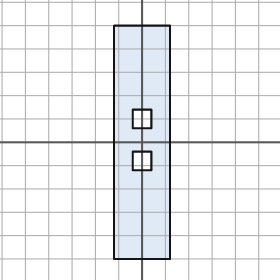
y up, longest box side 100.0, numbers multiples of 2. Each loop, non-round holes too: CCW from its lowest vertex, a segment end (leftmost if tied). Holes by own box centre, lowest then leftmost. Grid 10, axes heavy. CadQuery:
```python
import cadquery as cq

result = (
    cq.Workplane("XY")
    .moveTo(-12.0, -50.0)
    .lineTo(12.0, -50.0)
    .lineTo(12.0, 50.0)
    .lineTo(-12.0, 50.0)
    .close()
    .moveTo(-4.0, -12.0)
    .lineTo(4.0, -12.0)
    .lineTo(4.0, -4.0)
    .lineTo(-4.0, -4.0)
    .close()
    .moveTo(-4.0, 6.0)
    .lineTo(4.0, 6.0)
    .lineTo(4.0, 14.0)
    .lineTo(-4.0, 14.0)
    .close()
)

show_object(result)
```